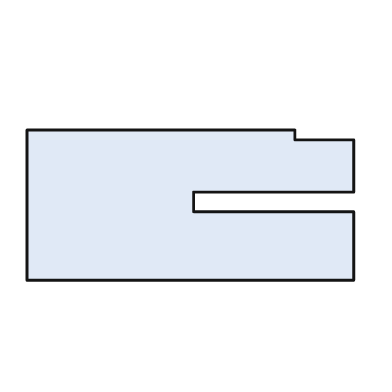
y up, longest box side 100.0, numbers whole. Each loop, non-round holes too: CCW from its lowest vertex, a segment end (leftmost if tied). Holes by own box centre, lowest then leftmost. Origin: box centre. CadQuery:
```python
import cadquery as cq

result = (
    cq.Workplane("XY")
    .moveTo(-50.0, -23.0)
    .lineTo(50.0, -23.0)
    .lineTo(50.0, -2.0)
    .lineTo(1.0, -2.0)
    .lineTo(1.0, 4.0)
    .lineTo(50.0, 4.0)
    .lineTo(50.0, 20.0)
    .lineTo(32.0, 20.0)
    .lineTo(32.0, 23.0)
    .lineTo(-50.0, 23.0)
    .close()
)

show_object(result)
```